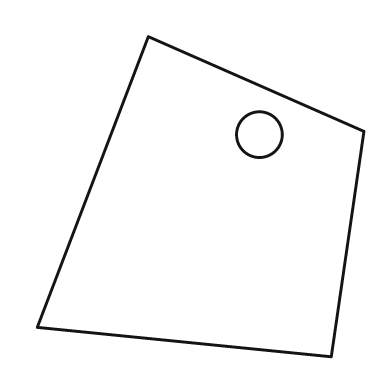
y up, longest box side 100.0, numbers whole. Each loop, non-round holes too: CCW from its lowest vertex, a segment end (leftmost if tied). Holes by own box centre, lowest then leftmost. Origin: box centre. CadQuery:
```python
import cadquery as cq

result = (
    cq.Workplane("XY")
    .moveTo(40.0, -49.0)
    .lineTo(50.0, 20.0)
    .lineTo(-16.0, 49.0)
    .lineTo(-50.0, -40.0)
    .close()
    .moveTo(18.0, 19.0)
    .circle(7.0)
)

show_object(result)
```